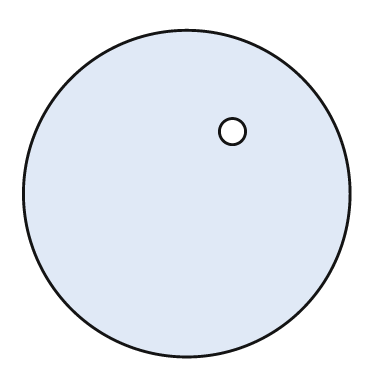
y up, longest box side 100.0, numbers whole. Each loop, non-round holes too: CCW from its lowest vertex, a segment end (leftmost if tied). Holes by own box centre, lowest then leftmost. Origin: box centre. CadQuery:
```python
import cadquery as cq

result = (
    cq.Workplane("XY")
    .moveTo(0.0, 0.0)
    .circle(50.0)
    .moveTo(14.0, 19.0)
    .circle(4.0)
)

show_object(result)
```